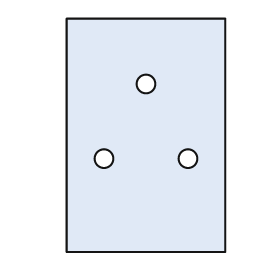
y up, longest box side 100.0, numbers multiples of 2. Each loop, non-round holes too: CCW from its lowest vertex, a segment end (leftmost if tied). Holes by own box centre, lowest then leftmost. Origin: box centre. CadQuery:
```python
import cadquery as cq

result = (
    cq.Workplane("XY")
    .moveTo(-34.0, -50.0)
    .lineTo(34.0, -50.0)
    .lineTo(34.0, 50.0)
    .lineTo(-34.0, 50.0)
    .close()
    .moveTo(-18.0, -10.0)
    .circle(4.0)
    .moveTo(18.0, -10.0)
    .circle(4.0)
    .moveTo(0.0, 22.0)
    .circle(4.0)
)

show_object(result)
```